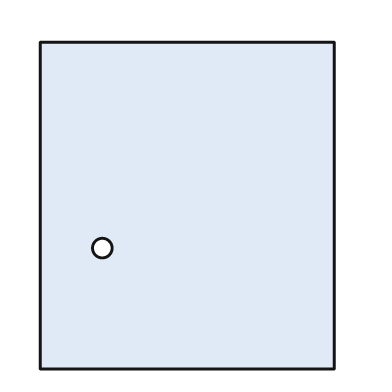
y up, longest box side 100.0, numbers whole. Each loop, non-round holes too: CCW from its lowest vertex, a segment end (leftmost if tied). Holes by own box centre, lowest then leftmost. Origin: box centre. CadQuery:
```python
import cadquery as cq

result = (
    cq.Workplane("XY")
    .moveTo(-45.0, -50.0)
    .lineTo(45.0, -50.0)
    .lineTo(45.0, 50.0)
    .lineTo(-45.0, 50.0)
    .close()
    .moveTo(-26.0, -13.0)
    .circle(3.0)
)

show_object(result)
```